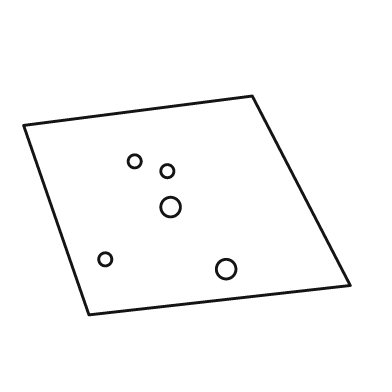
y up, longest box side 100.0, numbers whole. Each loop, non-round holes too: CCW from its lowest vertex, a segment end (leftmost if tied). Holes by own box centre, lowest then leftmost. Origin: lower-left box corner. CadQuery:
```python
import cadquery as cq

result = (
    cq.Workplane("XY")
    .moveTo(20.0, 0.0)
    .lineTo(100.0, 9.0)
    .lineTo(70.0, 67.0)
    .lineTo(0.0, 58.0)
    .close()
    .moveTo(62.0, 14.0)
    .circle(3.0)
    .moveTo(25.0, 17.0)
    .circle(2.0)
    .moveTo(45.0, 33.0)
    .circle(3.0)
    .moveTo(44.0, 44.0)
    .circle(2.0)
    .moveTo(34.0, 47.0)
    .circle(2.0)
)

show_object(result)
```